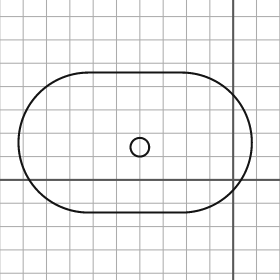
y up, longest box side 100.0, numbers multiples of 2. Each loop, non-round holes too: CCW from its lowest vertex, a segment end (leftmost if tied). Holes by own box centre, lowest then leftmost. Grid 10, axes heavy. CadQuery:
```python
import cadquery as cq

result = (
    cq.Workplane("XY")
    .moveTo(-62.0, -14.0)
    .lineTo(-22.0, -14.0)
    .threePointArc((8.0, 16.0), (-22.0, 46.0))
    .lineTo(-62.0, 46.0)
    .threePointArc((-92.0, 16.0), (-62.0, -14.0))
    .close()
    .moveTo(-40.0, 14.0)
    .circle(4.0)
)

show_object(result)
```